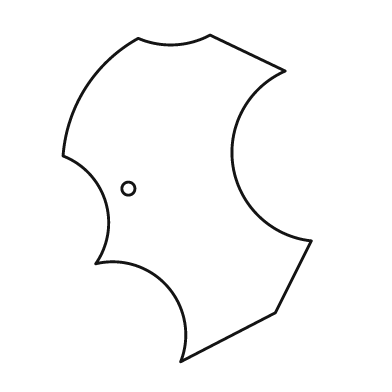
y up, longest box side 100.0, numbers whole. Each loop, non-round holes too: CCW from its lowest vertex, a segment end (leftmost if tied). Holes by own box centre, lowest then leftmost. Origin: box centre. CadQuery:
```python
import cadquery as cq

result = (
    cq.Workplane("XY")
    .moveTo(-2.0, -50.0)
    .lineTo(27.0, -35.0)
    .lineTo(38.0, -13.0)
    .threePointArc((14.0, 10.0), (30.0, 39.0))
    .lineTo(7.0, 50.0)
    .threePointArc((-4.0, 47.0), (-15.0, 49.0))
    .threePointArc((-31.0, 34.0), (-38.0, 13.0))
    .threePointArc((-25.0, -1.0), (-28.0, -20.0))
    .threePointArc((-6.0, -27.0), (-2.0, -50.0))
    .close()
    .moveTo(-18.0, 3.0)
    .circle(2.0)
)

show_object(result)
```